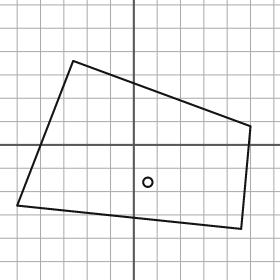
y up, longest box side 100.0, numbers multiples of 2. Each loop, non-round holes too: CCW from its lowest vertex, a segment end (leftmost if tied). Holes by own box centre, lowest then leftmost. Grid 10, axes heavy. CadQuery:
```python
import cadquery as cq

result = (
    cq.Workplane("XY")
    .moveTo(46.0, -36.0)
    .lineTo(50.0, 8.0)
    .lineTo(-26.0, 36.0)
    .lineTo(-50.0, -26.0)
    .close()
    .moveTo(6.0, -16.0)
    .circle(2.0)
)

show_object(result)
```